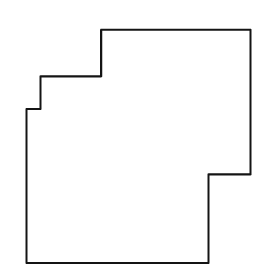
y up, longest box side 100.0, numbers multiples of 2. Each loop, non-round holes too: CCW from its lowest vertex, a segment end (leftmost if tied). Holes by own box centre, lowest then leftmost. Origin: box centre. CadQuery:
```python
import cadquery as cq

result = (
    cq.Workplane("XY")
    .moveTo(-48.0, -50.0)
    .lineTo(30.0, -50.0)
    .lineTo(30.0, -12.0)
    .lineTo(48.0, -12.0)
    .lineTo(48.0, 50.0)
    .lineTo(-16.0, 50.0)
    .lineTo(-16.0, 30.0)
    .lineTo(-42.0, 30.0)
    .lineTo(-42.0, 16.0)
    .lineTo(-48.0, 16.0)
    .close()
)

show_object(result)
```